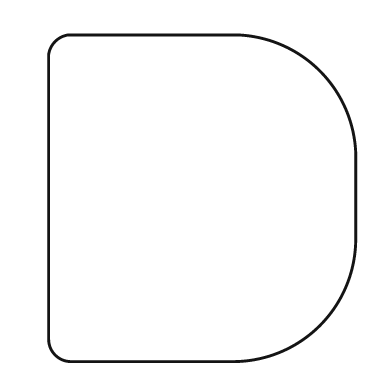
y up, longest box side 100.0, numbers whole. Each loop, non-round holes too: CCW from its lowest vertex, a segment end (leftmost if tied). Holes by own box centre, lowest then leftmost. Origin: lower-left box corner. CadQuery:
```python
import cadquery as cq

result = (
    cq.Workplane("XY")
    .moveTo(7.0, 0.0)
    .lineTo(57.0, 0.0)
    .threePointArc((83.0, 11.0), (94.0, 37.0))
    .lineTo(94.0, 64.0)
    .threePointArc((83.0, 89.0), (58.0, 100.0))
    .lineTo(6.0, 100.0)
    .threePointArc((2.0, 98.0), (0.0, 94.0))
    .lineTo(0.0, 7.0)
    .threePointArc((2.0, 2.0), (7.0, 0.0))
    .close()
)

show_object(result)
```